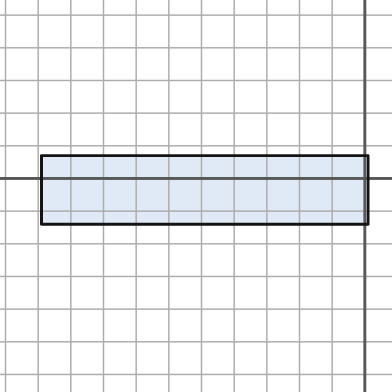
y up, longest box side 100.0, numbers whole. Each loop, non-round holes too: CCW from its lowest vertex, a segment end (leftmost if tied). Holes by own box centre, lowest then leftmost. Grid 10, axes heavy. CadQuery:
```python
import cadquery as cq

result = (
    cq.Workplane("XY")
    .moveTo(-99.0, -14.0)
    .lineTo(1.0, -14.0)
    .lineTo(1.0, 7.0)
    .lineTo(-99.0, 7.0)
    .close()
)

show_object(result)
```